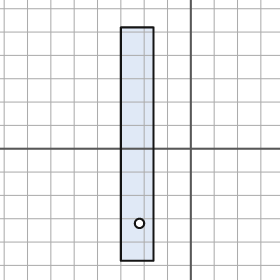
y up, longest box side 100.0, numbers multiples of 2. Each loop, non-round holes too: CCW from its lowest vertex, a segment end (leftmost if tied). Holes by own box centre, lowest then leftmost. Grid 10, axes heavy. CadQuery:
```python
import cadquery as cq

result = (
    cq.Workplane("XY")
    .moveTo(-30.0, -48.0)
    .lineTo(-16.0, -48.0)
    .lineTo(-16.0, 52.0)
    .lineTo(-30.0, 52.0)
    .close()
    .moveTo(-22.0, -32.0)
    .circle(2.0)
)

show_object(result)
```